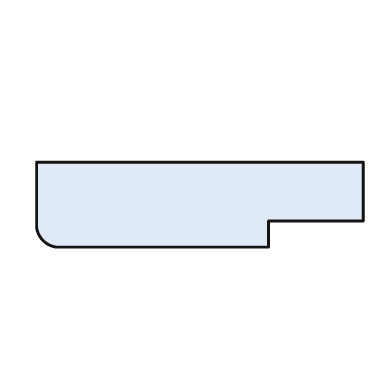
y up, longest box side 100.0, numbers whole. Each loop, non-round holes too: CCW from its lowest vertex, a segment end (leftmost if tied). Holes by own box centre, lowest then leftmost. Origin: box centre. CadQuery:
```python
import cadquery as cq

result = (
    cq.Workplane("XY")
    .moveTo(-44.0, -13.0)
    .lineTo(21.0, -13.0)
    .lineTo(21.0, -5.0)
    .lineTo(50.0, -5.0)
    .lineTo(50.0, 13.0)
    .lineTo(-50.0, 13.0)
    .lineTo(-50.0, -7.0)
    .threePointArc((-48.0, -11.0), (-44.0, -13.0))
    .close()
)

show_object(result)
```